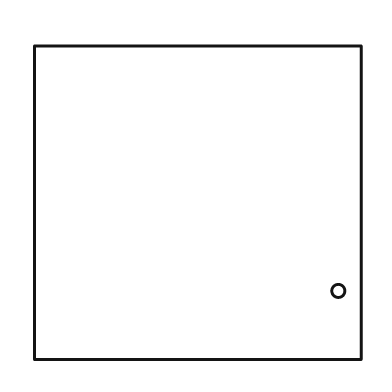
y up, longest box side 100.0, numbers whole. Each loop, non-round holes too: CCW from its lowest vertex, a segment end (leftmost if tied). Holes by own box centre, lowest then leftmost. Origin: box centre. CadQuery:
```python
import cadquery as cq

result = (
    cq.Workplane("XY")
    .moveTo(-50.0, -48.0)
    .lineTo(50.0, -48.0)
    .lineTo(50.0, 48.0)
    .lineTo(-50.0, 48.0)
    .close()
    .moveTo(43.0, -27.0)
    .circle(2.0)
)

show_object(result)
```